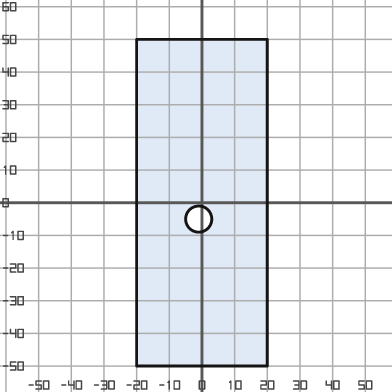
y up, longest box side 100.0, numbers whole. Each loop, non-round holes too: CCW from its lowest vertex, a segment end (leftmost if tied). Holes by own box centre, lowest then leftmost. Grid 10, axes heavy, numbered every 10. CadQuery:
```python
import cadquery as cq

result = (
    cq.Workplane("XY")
    .moveTo(-20.0, -50.0)
    .lineTo(20.0, -50.0)
    .lineTo(20.0, 50.0)
    .lineTo(-20.0, 50.0)
    .close()
    .moveTo(-1.0, -5.0)
    .circle(4.0)
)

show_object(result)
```